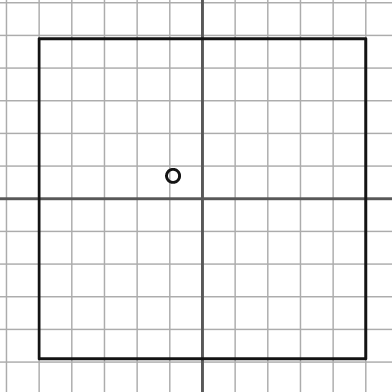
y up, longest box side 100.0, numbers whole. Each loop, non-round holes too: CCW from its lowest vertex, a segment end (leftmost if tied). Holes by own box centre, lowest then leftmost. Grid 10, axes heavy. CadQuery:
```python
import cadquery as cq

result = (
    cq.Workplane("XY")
    .moveTo(-50.0, -49.0)
    .lineTo(50.0, -49.0)
    .lineTo(50.0, 49.0)
    .lineTo(-50.0, 49.0)
    .close()
    .moveTo(-9.0, 7.0)
    .circle(2.0)
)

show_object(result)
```